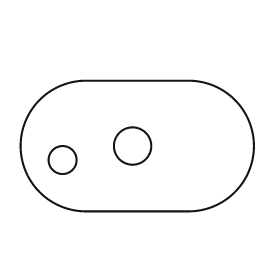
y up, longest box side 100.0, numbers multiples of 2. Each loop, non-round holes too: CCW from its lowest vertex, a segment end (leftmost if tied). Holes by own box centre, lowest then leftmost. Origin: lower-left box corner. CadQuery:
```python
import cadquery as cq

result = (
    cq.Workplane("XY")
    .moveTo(28.0, 0.0)
    .lineTo(72.0, 0.0)
    .threePointArc((100.0, 28.0), (72.0, 56.0))
    .lineTo(28.0, 56.0)
    .threePointArc((0.0, 28.0), (28.0, 0.0))
    .close()
    .moveTo(18.0, 22.0)
    .circle(6.0)
    .moveTo(48.0, 28.0)
    .circle(8.0)
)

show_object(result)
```